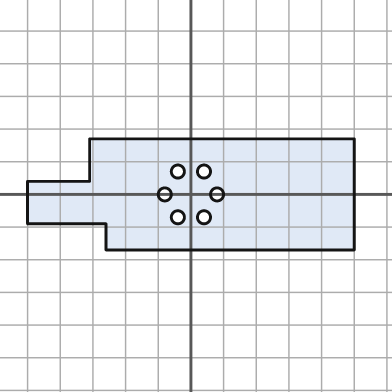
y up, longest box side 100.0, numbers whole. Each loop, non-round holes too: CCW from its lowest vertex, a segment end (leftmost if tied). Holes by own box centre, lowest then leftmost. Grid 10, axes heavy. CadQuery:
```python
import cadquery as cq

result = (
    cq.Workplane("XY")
    .moveTo(-26.0, -17.0)
    .lineTo(50.0, -17.0)
    .lineTo(50.0, 17.0)
    .lineTo(-31.0, 17.0)
    .lineTo(-31.0, 4.0)
    .lineTo(-50.0, 4.0)
    .lineTo(-50.0, -9.0)
    .lineTo(-26.0, -9.0)
    .close()
    .moveTo(-4.0, -7.0)
    .circle(2.0)
    .moveTo(4.0, -7.0)
    .circle(2.0)
    .moveTo(-8.0, 0.0)
    .circle(2.0)
    .moveTo(8.0, 0.0)
    .circle(2.0)
    .moveTo(-4.0, 7.0)
    .circle(2.0)
    .moveTo(4.0, 7.0)
    .circle(2.0)
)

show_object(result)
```